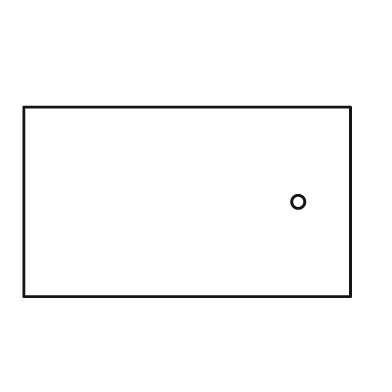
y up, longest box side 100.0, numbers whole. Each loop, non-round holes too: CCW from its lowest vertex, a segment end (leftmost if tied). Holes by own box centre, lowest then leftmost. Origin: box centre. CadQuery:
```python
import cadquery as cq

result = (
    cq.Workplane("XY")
    .moveTo(-50.0, -29.0)
    .lineTo(50.0, -29.0)
    .lineTo(50.0, 29.0)
    .lineTo(-50.0, 29.0)
    .close()
    .moveTo(34.0, 0.0)
    .circle(2.0)
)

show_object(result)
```